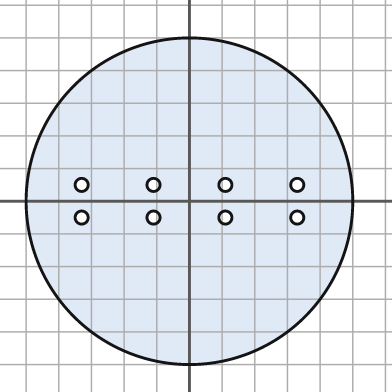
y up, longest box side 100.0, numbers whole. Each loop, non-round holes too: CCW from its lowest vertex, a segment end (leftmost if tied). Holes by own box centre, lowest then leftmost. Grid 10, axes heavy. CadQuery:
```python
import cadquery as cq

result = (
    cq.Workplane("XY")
    .moveTo(0.0, 0.0)
    .circle(50.0)
    .moveTo(-33.0, -5.0)
    .circle(2.0)
    .moveTo(-11.0, -5.0)
    .circle(2.0)
    .moveTo(11.0, -5.0)
    .circle(2.0)
    .moveTo(33.0, -5.0)
    .circle(2.0)
    .moveTo(-33.0, 5.0)
    .circle(2.0)
    .moveTo(-11.0, 5.0)
    .circle(2.0)
    .moveTo(11.0, 5.0)
    .circle(2.0)
    .moveTo(33.0, 5.0)
    .circle(2.0)
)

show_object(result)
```